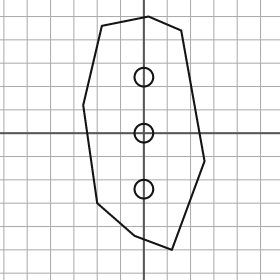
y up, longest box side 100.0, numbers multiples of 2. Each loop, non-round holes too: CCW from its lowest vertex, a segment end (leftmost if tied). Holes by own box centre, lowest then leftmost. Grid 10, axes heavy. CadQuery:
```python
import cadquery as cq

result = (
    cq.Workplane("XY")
    .moveTo(12.0, -50.0)
    .lineTo(26.0, -12.0)
    .lineTo(16.0, 44.0)
    .lineTo(2.0, 50.0)
    .lineTo(-18.0, 46.0)
    .lineTo(-26.0, 12.0)
    .lineTo(-20.0, -30.0)
    .lineTo(-4.0, -44.0)
    .close()
    .moveTo(0.0, -24.0)
    .circle(4.0)
    .moveTo(0.0, 0.0)
    .circle(4.0)
    .moveTo(0.0, 24.0)
    .circle(4.0)
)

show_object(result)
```